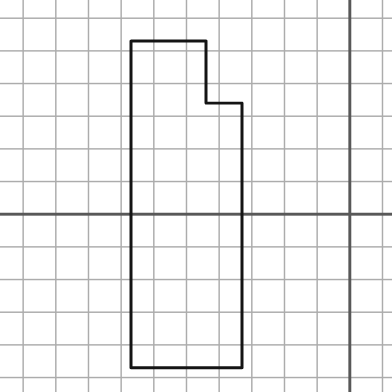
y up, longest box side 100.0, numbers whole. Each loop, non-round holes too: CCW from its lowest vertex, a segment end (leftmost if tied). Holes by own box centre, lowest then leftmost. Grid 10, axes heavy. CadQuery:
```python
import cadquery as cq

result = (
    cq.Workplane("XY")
    .moveTo(-67.0, -47.0)
    .lineTo(-33.0, -47.0)
    .lineTo(-33.0, 34.0)
    .lineTo(-44.0, 34.0)
    .lineTo(-44.0, 53.0)
    .lineTo(-67.0, 53.0)
    .close()
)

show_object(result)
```